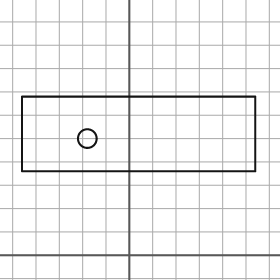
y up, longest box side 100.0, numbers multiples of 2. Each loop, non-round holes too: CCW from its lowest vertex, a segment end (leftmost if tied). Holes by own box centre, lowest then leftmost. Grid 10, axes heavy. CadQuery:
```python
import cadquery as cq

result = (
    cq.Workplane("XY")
    .moveTo(-46.0, 36.0)
    .lineTo(54.0, 36.0)
    .lineTo(54.0, 68.0)
    .lineTo(-46.0, 68.0)
    .close()
    .moveTo(-18.0, 50.0)
    .circle(4.0)
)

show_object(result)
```